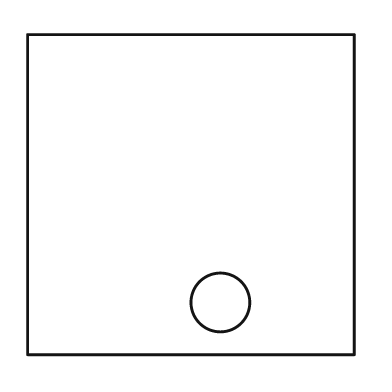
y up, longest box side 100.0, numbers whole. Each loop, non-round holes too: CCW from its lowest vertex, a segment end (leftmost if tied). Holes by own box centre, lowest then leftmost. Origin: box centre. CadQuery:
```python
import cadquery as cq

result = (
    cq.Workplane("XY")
    .moveTo(-50.0, -49.0)
    .lineTo(50.0, -49.0)
    .lineTo(50.0, 49.0)
    .lineTo(-50.0, 49.0)
    .close()
    .moveTo(9.0, -33.0)
    .circle(9.0)
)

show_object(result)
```